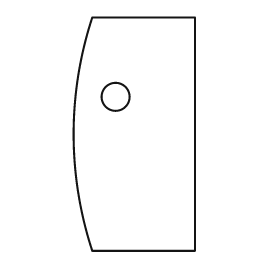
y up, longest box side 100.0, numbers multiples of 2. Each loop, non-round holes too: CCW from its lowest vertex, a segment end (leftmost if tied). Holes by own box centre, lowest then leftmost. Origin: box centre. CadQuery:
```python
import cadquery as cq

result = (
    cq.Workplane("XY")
    .moveTo(-18.0, -50.0)
    .lineTo(26.0, -50.0)
    .lineTo(26.0, 50.0)
    .lineTo(-18.0, 50.0)
    .threePointArc((-26.0, 0.0), (-18.0, -50.0))
    .close()
    .moveTo(-8.0, 16.0)
    .circle(6.0)
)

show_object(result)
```